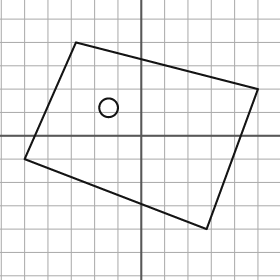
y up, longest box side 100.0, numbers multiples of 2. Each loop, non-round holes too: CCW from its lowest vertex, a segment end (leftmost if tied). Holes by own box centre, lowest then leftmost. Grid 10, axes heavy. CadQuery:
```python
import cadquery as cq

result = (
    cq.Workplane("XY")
    .moveTo(28.0, -40.0)
    .lineTo(50.0, 20.0)
    .lineTo(-28.0, 40.0)
    .lineTo(-50.0, -10.0)
    .close()
    .moveTo(-14.0, 12.0)
    .circle(4.0)
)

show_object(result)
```